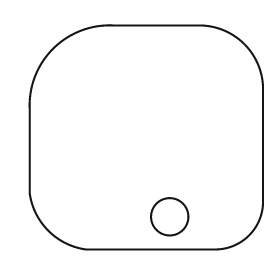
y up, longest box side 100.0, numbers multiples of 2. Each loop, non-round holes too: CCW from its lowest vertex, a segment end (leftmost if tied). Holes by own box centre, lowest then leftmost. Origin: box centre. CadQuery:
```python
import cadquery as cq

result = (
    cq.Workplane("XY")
    .moveTo(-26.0, -48.0)
    .lineTo(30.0, -48.0)
    .threePointArc((44.0, -42.0), (50.0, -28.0))
    .lineTo(50.0, 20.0)
    .threePointArc((42.0, 40.0), (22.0, 48.0))
    .lineTo(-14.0, 48.0)
    .threePointArc((-40.0, 38.0), (-50.0, 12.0))
    .lineTo(-50.0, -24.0)
    .threePointArc((-42.0, -40.0), (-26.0, -48.0))
    .close()
    .moveTo(10.0, -34.0)
    .circle(8.0)
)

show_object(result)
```